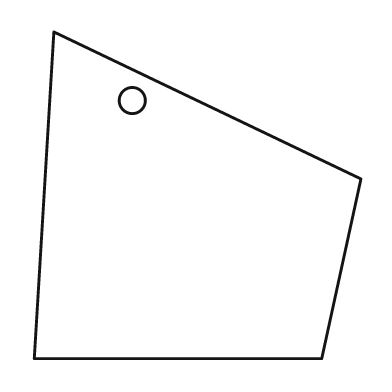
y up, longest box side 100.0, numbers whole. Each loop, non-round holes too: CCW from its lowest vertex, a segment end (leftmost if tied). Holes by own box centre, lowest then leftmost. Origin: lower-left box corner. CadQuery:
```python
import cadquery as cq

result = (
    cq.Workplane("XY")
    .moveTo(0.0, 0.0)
    .lineTo(88.0, 0.0)
    .lineTo(100.0, 55.0)
    .lineTo(6.0, 100.0)
    .close()
    .moveTo(30.0, 79.0)
    .circle(4.0)
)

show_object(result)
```